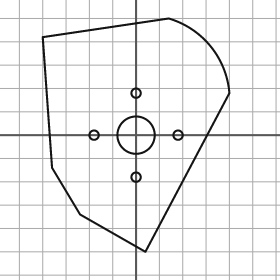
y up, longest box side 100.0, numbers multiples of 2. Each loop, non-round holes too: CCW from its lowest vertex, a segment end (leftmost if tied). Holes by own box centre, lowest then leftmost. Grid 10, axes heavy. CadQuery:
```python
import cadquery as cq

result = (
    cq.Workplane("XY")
    .moveTo(4.0, -50.0)
    .lineTo(40.0, 18.0)
    .threePointArc((32.0, 38.0), (14.0, 50.0))
    .lineTo(-40.0, 42.0)
    .lineTo(-36.0, -14.0)
    .lineTo(-24.0, -34.0)
    .close()
    .moveTo(0.0, -18.0)
    .circle(2.0)
    .moveTo(-18.0, 0.0)
    .circle(2.0)
    .moveTo(0.0, 0.0)
    .circle(8.0)
    .moveTo(18.0, 0.0)
    .circle(2.0)
    .moveTo(0.0, 18.0)
    .circle(2.0)
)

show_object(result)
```